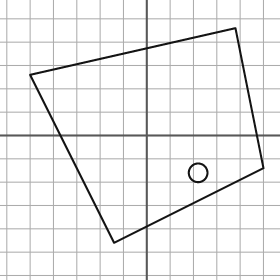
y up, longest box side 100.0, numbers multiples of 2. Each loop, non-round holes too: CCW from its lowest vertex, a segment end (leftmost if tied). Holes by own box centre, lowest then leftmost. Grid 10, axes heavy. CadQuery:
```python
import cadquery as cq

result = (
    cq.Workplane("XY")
    .moveTo(-14.0, -46.0)
    .lineTo(50.0, -14.0)
    .lineTo(38.0, 46.0)
    .lineTo(-50.0, 26.0)
    .close()
    .moveTo(22.0, -16.0)
    .circle(4.0)
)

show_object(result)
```